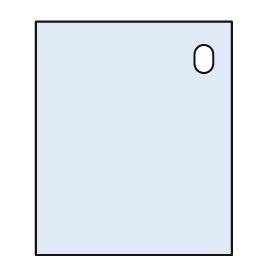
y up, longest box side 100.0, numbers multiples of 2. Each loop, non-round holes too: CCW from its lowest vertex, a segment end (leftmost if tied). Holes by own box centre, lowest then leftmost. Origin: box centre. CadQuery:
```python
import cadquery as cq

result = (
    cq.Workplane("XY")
    .moveTo(-42.0, -50.0)
    .lineTo(42.0, -50.0)
    .lineTo(42.0, 50.0)
    .lineTo(-42.0, 50.0)
    .close()
    .moveTo(26.0, 32.0)
    .threePointArc((30.0, 28.0), (34.0, 32.0))
    .lineTo(34.0, 36.0)
    .threePointArc((30.0, 40.0), (26.0, 36.0))
    .close()
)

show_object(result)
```